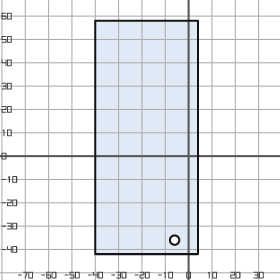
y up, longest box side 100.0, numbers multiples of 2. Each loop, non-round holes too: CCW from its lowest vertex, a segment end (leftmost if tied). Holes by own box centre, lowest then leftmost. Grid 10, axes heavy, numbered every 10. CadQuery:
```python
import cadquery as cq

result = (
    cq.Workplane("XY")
    .moveTo(-40.0, -42.0)
    .lineTo(4.0, -42.0)
    .lineTo(4.0, 58.0)
    .lineTo(-40.0, 58.0)
    .close()
    .moveTo(-6.0, -36.0)
    .circle(2.0)
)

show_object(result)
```